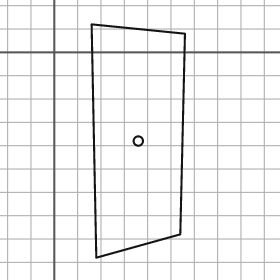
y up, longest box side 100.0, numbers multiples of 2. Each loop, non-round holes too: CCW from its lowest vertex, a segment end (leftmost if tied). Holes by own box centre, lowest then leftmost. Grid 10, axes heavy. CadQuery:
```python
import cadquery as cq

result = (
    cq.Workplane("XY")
    .moveTo(18.0, -88.0)
    .lineTo(54.0, -78.0)
    .lineTo(56.0, 8.0)
    .lineTo(16.0, 12.0)
    .close()
    .moveTo(36.0, -38.0)
    .circle(2.0)
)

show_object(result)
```